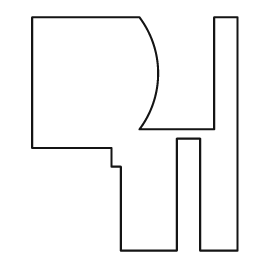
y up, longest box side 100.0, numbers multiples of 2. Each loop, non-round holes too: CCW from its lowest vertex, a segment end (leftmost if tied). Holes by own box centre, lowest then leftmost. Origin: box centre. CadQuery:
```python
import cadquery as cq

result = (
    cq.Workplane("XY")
    .moveTo(-6.0, -50.0)
    .lineTo(18.0, -50.0)
    .lineTo(18.0, -2.0)
    .lineTo(28.0, -2.0)
    .lineTo(28.0, -50.0)
    .lineTo(44.0, -50.0)
    .lineTo(44.0, 50.0)
    .lineTo(34.0, 50.0)
    .lineTo(34.0, 2.0)
    .lineTo(2.0, 2.0)
    .threePointArc((10.0, 26.0), (2.0, 50.0))
    .lineTo(-44.0, 50.0)
    .lineTo(-44.0, -6.0)
    .lineTo(-10.0, -6.0)
    .lineTo(-10.0, -14.0)
    .lineTo(-6.0, -14.0)
    .close()
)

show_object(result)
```